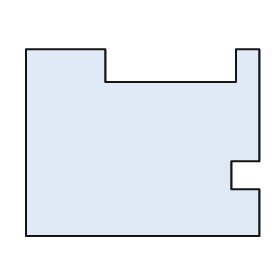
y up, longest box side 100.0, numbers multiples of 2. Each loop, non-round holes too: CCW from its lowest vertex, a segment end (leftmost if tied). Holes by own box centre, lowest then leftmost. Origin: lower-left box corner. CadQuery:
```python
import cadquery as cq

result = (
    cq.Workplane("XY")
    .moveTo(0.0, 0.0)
    .lineTo(100.0, 0.0)
    .lineTo(100.0, 20.0)
    .lineTo(88.0, 20.0)
    .lineTo(88.0, 32.0)
    .lineTo(100.0, 32.0)
    .lineTo(100.0, 80.0)
    .lineTo(90.0, 80.0)
    .lineTo(90.0, 66.0)
    .lineTo(34.0, 66.0)
    .lineTo(34.0, 80.0)
    .lineTo(0.0, 80.0)
    .close()
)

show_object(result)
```